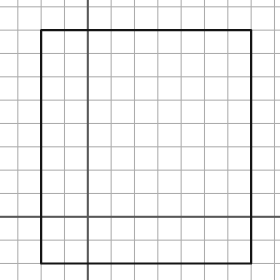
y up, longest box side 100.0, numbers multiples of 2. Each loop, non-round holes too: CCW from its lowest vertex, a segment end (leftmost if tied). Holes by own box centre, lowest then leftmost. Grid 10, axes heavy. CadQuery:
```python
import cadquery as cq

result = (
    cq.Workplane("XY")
    .moveTo(-20.0, -20.0)
    .lineTo(70.0, -20.0)
    .lineTo(70.0, 80.0)
    .lineTo(-20.0, 80.0)
    .close()
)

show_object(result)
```